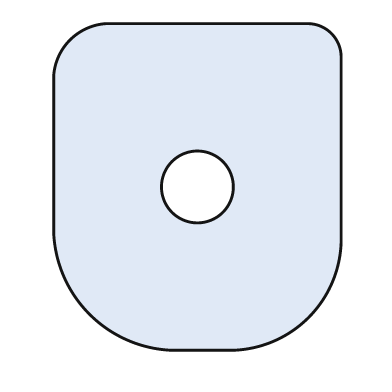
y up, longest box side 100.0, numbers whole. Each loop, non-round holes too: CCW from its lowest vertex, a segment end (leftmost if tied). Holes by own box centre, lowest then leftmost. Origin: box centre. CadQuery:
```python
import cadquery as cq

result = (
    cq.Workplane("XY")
    .moveTo(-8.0, -50.0)
    .lineTo(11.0, -50.0)
    .threePointArc((34.0, -40.0), (44.0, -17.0))
    .lineTo(44.0, 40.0)
    .threePointArc((41.0, 47.0), (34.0, 50.0))
    .lineTo(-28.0, 50.0)
    .threePointArc((-39.0, 45.0), (-44.0, 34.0))
    .lineTo(-44.0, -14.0)
    .threePointArc((-33.0, -39.0), (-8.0, -50.0))
    .close()
    .moveTo(0.0, 0.0)
    .circle(11.0)
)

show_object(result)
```